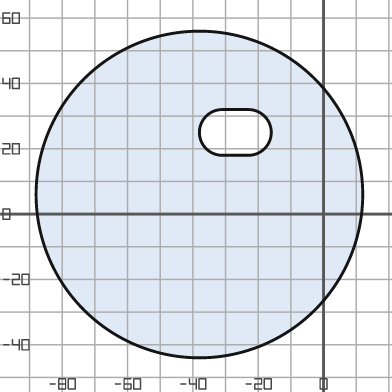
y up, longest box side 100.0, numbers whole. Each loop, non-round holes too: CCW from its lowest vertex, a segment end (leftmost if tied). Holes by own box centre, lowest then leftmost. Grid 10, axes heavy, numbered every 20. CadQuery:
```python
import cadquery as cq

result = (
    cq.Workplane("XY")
    .moveTo(-38.0, 6.0)
    .circle(50.0)
    .moveTo(-31.0, 18.0)
    .lineTo(-23.0, 18.0)
    .threePointArc((-16.0, 25.0), (-23.0, 32.0))
    .lineTo(-31.0, 32.0)
    .threePointArc((-38.0, 25.0), (-31.0, 18.0))
    .close()
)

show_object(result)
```